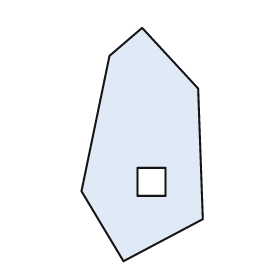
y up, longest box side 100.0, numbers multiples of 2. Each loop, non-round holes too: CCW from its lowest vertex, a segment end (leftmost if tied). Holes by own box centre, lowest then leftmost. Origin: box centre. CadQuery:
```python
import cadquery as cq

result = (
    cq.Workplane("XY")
    .moveTo(-8.0, -50.0)
    .lineTo(26.0, -32.0)
    .lineTo(24.0, 24.0)
    .lineTo(0.0, 50.0)
    .lineTo(-14.0, 38.0)
    .lineTo(-26.0, -20.0)
    .close()
    .moveTo(-2.0, -22.0)
    .lineTo(10.0, -22.0)
    .lineTo(10.0, -10.0)
    .lineTo(-2.0, -10.0)
    .close()
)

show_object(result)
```